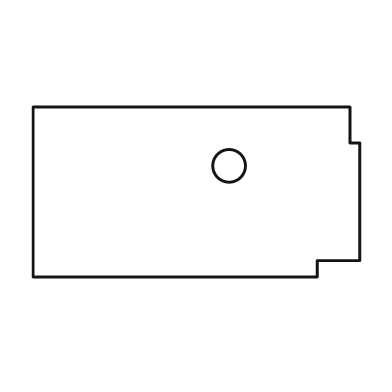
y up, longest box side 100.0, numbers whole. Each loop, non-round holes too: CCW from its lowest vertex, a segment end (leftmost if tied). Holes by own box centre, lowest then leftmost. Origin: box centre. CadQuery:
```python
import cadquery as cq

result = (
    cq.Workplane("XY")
    .moveTo(-50.0, -26.0)
    .lineTo(37.0, -26.0)
    .lineTo(37.0, -21.0)
    .lineTo(50.0, -21.0)
    .lineTo(50.0, 15.0)
    .lineTo(47.0, 15.0)
    .lineTo(47.0, 26.0)
    .lineTo(-50.0, 26.0)
    .close()
    .moveTo(10.0, 8.0)
    .circle(5.0)
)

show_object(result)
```